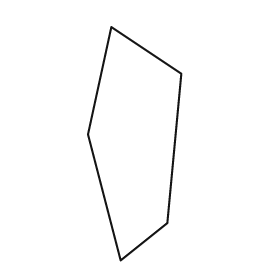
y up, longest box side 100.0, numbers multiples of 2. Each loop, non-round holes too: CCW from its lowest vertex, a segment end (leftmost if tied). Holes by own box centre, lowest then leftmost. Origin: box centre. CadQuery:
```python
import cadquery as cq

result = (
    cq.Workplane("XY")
    .moveTo(-6.0, -50.0)
    .lineTo(14.0, -34.0)
    .lineTo(20.0, 30.0)
    .lineTo(-10.0, 50.0)
    .lineTo(-20.0, 4.0)
    .close()
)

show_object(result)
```